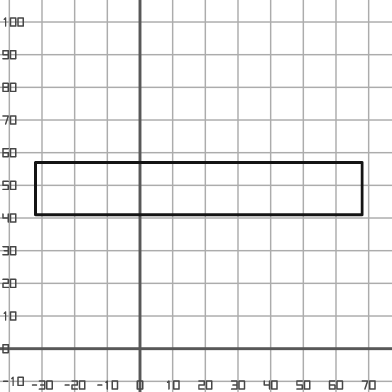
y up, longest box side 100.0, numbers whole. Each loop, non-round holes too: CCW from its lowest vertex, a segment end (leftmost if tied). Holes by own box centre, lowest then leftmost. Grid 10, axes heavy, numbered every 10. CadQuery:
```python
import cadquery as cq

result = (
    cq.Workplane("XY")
    .moveTo(-32.0, 41.0)
    .lineTo(68.0, 41.0)
    .lineTo(68.0, 57.0)
    .lineTo(-32.0, 57.0)
    .close()
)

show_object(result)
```